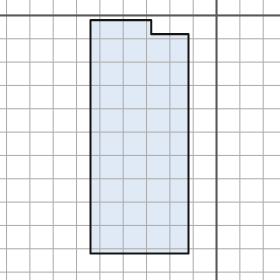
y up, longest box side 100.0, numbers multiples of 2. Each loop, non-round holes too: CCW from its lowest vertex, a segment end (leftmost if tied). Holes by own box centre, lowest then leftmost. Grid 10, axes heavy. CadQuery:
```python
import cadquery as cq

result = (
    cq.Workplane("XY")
    .moveTo(-54.0, -102.0)
    .lineTo(-12.0, -102.0)
    .lineTo(-12.0, -8.0)
    .lineTo(-28.0, -8.0)
    .lineTo(-28.0, -2.0)
    .lineTo(-54.0, -2.0)
    .close()
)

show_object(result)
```